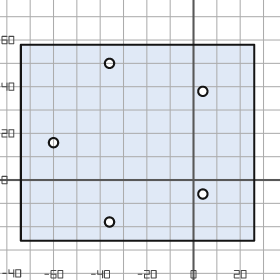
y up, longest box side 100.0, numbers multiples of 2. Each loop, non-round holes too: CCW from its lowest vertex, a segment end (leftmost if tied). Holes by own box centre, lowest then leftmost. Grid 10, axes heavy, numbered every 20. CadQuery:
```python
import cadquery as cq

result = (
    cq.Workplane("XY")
    .moveTo(-74.0, -26.0)
    .lineTo(26.0, -26.0)
    .lineTo(26.0, 58.0)
    .lineTo(-74.0, 58.0)
    .close()
    .moveTo(-36.0, -18.0)
    .circle(2.0)
    .moveTo(4.0, -6.0)
    .circle(2.0)
    .moveTo(-60.0, 16.0)
    .circle(2.0)
    .moveTo(4.0, 38.0)
    .circle(2.0)
    .moveTo(-36.0, 50.0)
    .circle(2.0)
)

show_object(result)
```